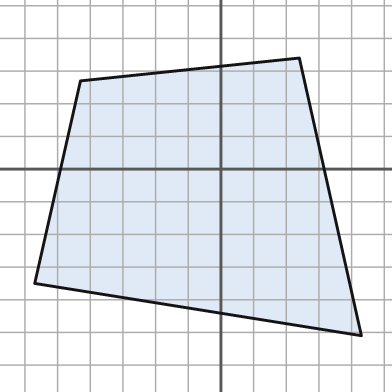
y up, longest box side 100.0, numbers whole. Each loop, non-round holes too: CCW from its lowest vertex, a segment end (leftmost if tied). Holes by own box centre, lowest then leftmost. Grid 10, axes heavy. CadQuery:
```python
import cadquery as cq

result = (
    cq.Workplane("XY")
    .moveTo(43.0, -51.0)
    .lineTo(24.0, 34.0)
    .lineTo(-43.0, 27.0)
    .lineTo(-57.0, -35.0)
    .close()
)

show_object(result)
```